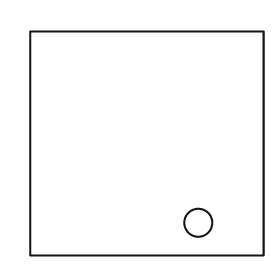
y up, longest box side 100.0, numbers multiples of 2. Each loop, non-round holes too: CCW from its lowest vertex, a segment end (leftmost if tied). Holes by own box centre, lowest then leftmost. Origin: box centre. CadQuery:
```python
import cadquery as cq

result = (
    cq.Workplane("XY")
    .moveTo(-50.0, -48.0)
    .lineTo(50.0, -48.0)
    .lineTo(50.0, 48.0)
    .lineTo(-50.0, 48.0)
    .close()
    .moveTo(22.0, -34.0)
    .circle(6.0)
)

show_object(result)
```